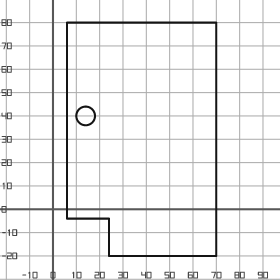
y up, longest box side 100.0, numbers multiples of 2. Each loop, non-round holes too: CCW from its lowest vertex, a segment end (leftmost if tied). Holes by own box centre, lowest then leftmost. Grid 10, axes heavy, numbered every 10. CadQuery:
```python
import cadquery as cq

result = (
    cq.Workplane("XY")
    .moveTo(24.0, -20.0)
    .lineTo(70.0, -20.0)
    .lineTo(70.0, 80.0)
    .lineTo(6.0, 80.0)
    .lineTo(6.0, -4.0)
    .lineTo(24.0, -4.0)
    .close()
    .moveTo(14.0, 40.0)
    .circle(4.0)
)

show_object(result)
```